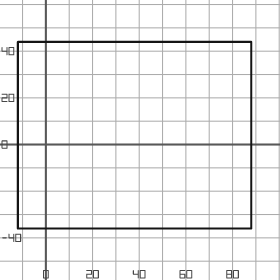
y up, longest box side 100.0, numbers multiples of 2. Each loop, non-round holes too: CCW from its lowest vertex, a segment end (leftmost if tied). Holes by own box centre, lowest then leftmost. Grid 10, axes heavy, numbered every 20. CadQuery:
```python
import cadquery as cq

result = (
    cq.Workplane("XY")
    .moveTo(-12.0, -36.0)
    .lineTo(88.0, -36.0)
    .lineTo(88.0, 44.0)
    .lineTo(-12.0, 44.0)
    .close()
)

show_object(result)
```